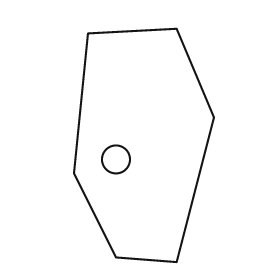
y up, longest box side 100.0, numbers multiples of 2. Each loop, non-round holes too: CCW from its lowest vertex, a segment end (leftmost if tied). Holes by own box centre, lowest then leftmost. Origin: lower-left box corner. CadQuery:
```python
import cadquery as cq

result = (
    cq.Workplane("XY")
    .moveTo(44.0, 0.0)
    .lineTo(60.0, 62.0)
    .lineTo(44.0, 100.0)
    .lineTo(6.0, 98.0)
    .lineTo(0.0, 38.0)
    .lineTo(18.0, 2.0)
    .close()
    .moveTo(18.0, 44.0)
    .circle(6.0)
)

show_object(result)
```